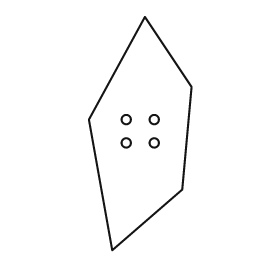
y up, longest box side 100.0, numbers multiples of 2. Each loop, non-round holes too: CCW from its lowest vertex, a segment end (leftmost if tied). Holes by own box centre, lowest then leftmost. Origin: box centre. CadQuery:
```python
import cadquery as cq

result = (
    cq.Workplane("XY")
    .moveTo(-12.0, -50.0)
    .lineTo(18.0, -24.0)
    .lineTo(22.0, 20.0)
    .lineTo(2.0, 50.0)
    .lineTo(-22.0, 6.0)
    .close()
    .moveTo(-6.0, -4.0)
    .circle(2.0)
    .moveTo(6.0, -4.0)
    .circle(2.0)
    .moveTo(-6.0, 6.0)
    .circle(2.0)
    .moveTo(6.0, 6.0)
    .circle(2.0)
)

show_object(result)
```